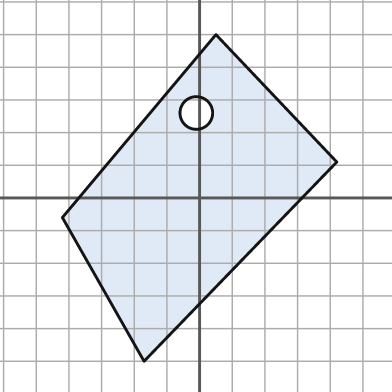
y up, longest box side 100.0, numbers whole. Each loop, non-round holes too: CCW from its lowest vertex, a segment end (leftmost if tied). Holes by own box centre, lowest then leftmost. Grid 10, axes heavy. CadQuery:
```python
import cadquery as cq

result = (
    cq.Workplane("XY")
    .moveTo(-17.0, -50.0)
    .lineTo(42.0, 11.0)
    .lineTo(5.0, 50.0)
    .lineTo(-42.0, -6.0)
    .close()
    .moveTo(-1.0, 26.0)
    .circle(5.0)
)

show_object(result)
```